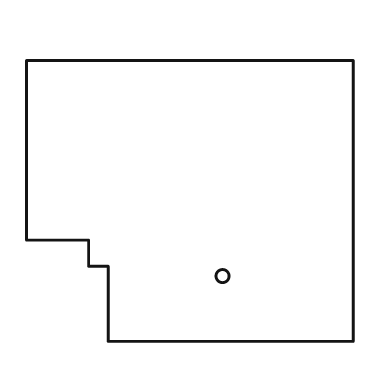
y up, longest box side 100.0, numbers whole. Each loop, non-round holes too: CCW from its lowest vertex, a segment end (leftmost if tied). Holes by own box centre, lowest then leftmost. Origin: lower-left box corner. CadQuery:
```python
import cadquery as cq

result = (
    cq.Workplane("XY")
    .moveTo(25.0, 0.0)
    .lineTo(100.0, 0.0)
    .lineTo(100.0, 86.0)
    .lineTo(0.0, 86.0)
    .lineTo(0.0, 31.0)
    .lineTo(19.0, 31.0)
    .lineTo(19.0, 23.0)
    .lineTo(25.0, 23.0)
    .close()
    .moveTo(60.0, 20.0)
    .circle(2.0)
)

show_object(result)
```